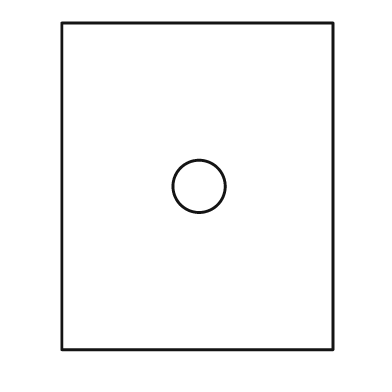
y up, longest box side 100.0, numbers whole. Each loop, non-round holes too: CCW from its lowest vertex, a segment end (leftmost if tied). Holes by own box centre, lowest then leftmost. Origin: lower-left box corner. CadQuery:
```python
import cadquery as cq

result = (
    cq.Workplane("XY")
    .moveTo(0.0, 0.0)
    .lineTo(83.0, 0.0)
    .lineTo(83.0, 100.0)
    .lineTo(0.0, 100.0)
    .close()
    .moveTo(42.0, 50.0)
    .circle(8.0)
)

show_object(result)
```